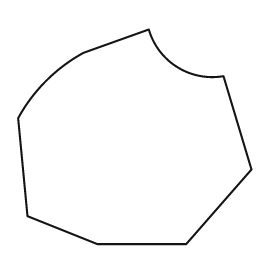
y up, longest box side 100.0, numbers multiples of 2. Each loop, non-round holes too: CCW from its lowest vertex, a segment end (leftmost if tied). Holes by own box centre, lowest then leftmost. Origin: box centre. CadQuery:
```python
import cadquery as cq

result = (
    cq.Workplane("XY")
    .moveTo(-16.0, -46.0)
    .lineTo(22.0, -46.0)
    .lineTo(50.0, -14.0)
    .lineTo(38.0, 26.0)
    .threePointArc((18.0, 30.0), (6.0, 46.0))
    .lineTo(-22.0, 36.0)
    .threePointArc((-38.0, 24.0), (-50.0, 8.0))
    .lineTo(-46.0, -34.0)
    .close()
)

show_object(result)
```